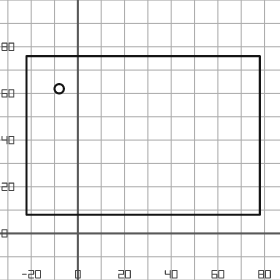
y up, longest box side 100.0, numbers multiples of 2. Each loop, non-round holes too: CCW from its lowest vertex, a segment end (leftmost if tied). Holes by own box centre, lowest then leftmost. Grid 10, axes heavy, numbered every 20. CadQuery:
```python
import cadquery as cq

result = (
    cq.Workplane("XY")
    .moveTo(-22.0, 8.0)
    .lineTo(78.0, 8.0)
    .lineTo(78.0, 76.0)
    .lineTo(-22.0, 76.0)
    .close()
    .moveTo(-8.0, 62.0)
    .circle(2.0)
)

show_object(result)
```